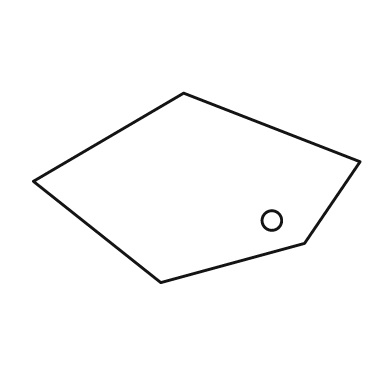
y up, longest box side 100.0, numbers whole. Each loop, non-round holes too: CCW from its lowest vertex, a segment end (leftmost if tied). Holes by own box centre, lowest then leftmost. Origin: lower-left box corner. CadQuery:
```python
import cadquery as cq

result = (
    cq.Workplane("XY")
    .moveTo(39.0, 0.0)
    .lineTo(83.0, 12.0)
    .lineTo(100.0, 37.0)
    .lineTo(46.0, 58.0)
    .lineTo(0.0, 31.0)
    .close()
    .moveTo(73.0, 19.0)
    .circle(3.0)
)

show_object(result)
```